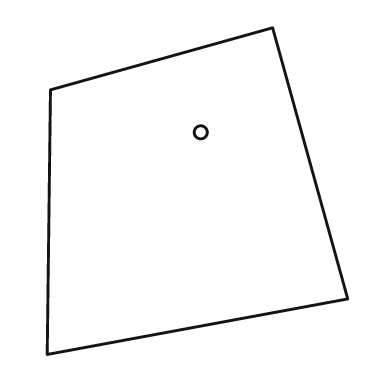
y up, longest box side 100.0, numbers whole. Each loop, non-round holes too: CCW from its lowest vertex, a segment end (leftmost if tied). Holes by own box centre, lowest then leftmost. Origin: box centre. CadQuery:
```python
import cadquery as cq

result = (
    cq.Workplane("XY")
    .moveTo(-46.0, -50.0)
    .lineTo(46.0, -33.0)
    .lineTo(23.0, 50.0)
    .lineTo(-45.0, 31.0)
    .close()
    .moveTo(1.0, 18.0)
    .circle(2.0)
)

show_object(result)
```